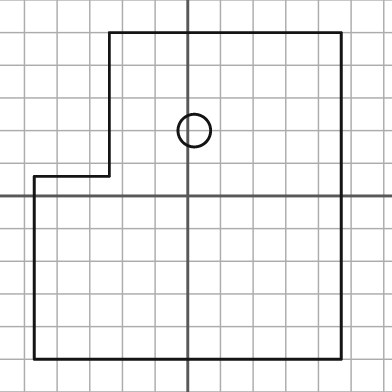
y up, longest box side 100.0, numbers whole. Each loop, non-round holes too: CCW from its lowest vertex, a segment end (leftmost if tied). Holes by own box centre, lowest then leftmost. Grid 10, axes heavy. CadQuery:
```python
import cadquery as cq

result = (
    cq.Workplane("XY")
    .moveTo(-47.0, -50.0)
    .lineTo(47.0, -50.0)
    .lineTo(47.0, 50.0)
    .lineTo(-24.0, 50.0)
    .lineTo(-24.0, 6.0)
    .lineTo(-47.0, 6.0)
    .close()
    .moveTo(2.0, 20.0)
    .circle(5.0)
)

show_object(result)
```